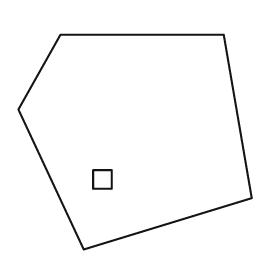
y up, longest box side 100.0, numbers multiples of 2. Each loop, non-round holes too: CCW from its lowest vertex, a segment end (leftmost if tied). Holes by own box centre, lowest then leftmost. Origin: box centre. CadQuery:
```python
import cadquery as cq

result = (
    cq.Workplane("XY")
    .moveTo(-22.0, -46.0)
    .lineTo(50.0, -24.0)
    .lineTo(38.0, 46.0)
    .lineTo(-32.0, 46.0)
    .lineTo(-50.0, 14.0)
    .close()
    .moveTo(-18.0, -20.0)
    .lineTo(-10.0, -20.0)
    .lineTo(-10.0, -12.0)
    .lineTo(-18.0, -12.0)
    .close()
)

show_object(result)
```